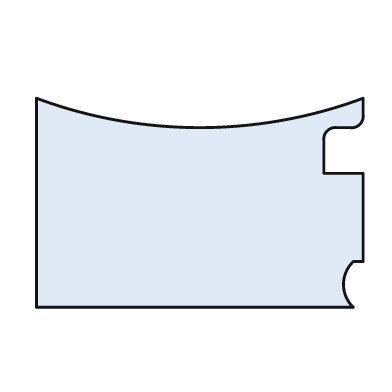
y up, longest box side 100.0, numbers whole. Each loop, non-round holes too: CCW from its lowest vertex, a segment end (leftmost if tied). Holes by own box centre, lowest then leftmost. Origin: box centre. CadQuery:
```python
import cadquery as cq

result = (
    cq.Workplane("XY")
    .moveTo(-50.0, -32.0)
    .lineTo(47.0, -32.0)
    .threePointArc((44.0, -25.0), (47.0, -18.0))
    .lineTo(50.0, -18.0)
    .lineTo(50.0, 9.0)
    .lineTo(38.0, 9.0)
    .lineTo(38.0, 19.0)
    .threePointArc((39.0, 22.0), (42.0, 23.0))
    .lineTo(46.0, 23.0)
    .threePointArc((49.0, 24.0), (50.0, 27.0))
    .lineTo(50.0, 32.0)
    .threePointArc((0.0, 23.0), (-50.0, 32.0))
    .close()
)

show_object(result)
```